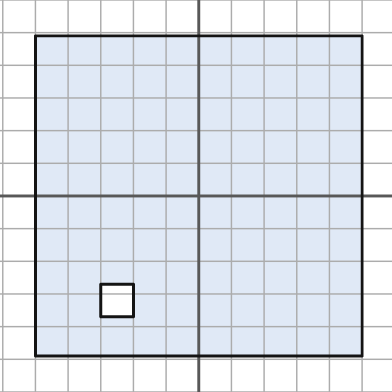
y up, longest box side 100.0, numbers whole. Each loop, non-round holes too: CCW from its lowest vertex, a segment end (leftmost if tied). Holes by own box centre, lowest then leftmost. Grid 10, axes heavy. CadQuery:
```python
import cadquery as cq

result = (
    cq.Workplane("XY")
    .moveTo(-50.0, -49.0)
    .lineTo(50.0, -49.0)
    .lineTo(50.0, 49.0)
    .lineTo(-50.0, 49.0)
    .close()
    .moveTo(-30.0, -37.0)
    .lineTo(-20.0, -37.0)
    .lineTo(-20.0, -27.0)
    .lineTo(-30.0, -27.0)
    .close()
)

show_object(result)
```